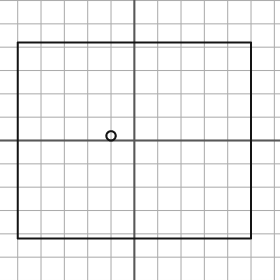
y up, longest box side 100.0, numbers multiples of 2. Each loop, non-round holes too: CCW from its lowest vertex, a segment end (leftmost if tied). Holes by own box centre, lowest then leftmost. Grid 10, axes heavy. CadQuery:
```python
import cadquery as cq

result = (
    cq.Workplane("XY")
    .moveTo(-50.0, -42.0)
    .lineTo(50.0, -42.0)
    .lineTo(50.0, 42.0)
    .lineTo(-50.0, 42.0)
    .close()
    .moveTo(-10.0, 2.0)
    .circle(2.0)
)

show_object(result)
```